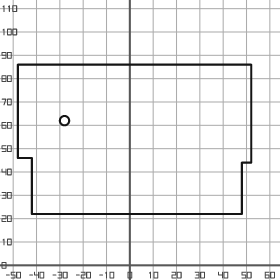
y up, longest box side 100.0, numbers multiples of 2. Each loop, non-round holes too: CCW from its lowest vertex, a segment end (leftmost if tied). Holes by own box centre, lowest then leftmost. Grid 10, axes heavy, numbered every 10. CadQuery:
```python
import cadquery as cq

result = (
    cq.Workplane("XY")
    .moveTo(-42.0, 22.0)
    .lineTo(48.0, 22.0)
    .lineTo(48.0, 44.0)
    .lineTo(52.0, 44.0)
    .lineTo(52.0, 86.0)
    .lineTo(-48.0, 86.0)
    .lineTo(-48.0, 46.0)
    .lineTo(-42.0, 46.0)
    .close()
    .moveTo(-28.0, 62.0)
    .circle(2.0)
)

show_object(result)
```